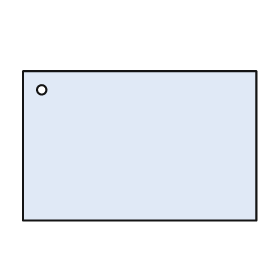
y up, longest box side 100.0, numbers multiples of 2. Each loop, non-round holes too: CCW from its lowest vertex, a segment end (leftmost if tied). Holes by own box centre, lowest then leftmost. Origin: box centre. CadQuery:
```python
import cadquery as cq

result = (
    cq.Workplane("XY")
    .moveTo(-50.0, -32.0)
    .lineTo(50.0, -32.0)
    .lineTo(50.0, 32.0)
    .lineTo(-50.0, 32.0)
    .close()
    .moveTo(-42.0, 24.0)
    .circle(2.0)
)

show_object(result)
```